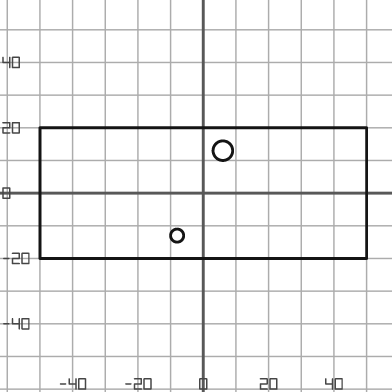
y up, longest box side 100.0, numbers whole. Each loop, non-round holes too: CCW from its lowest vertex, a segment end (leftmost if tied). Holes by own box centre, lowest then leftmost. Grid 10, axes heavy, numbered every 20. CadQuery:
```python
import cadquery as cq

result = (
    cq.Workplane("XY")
    .moveTo(-50.0, -20.0)
    .lineTo(50.0, -20.0)
    .lineTo(50.0, 20.0)
    .lineTo(-50.0, 20.0)
    .close()
    .moveTo(-8.0, -13.0)
    .circle(2.0)
    .moveTo(6.0, 13.0)
    .circle(3.0)
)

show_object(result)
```